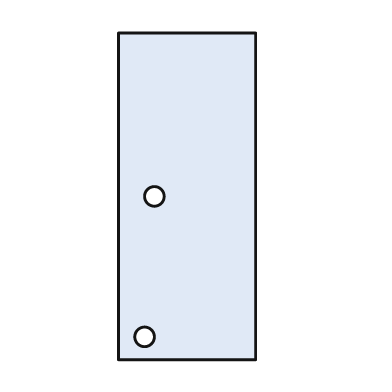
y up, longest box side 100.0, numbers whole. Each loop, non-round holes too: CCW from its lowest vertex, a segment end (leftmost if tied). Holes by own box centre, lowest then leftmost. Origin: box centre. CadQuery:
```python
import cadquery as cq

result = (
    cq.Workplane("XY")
    .moveTo(-21.0, -50.0)
    .lineTo(21.0, -50.0)
    .lineTo(21.0, 50.0)
    .lineTo(-21.0, 50.0)
    .close()
    .moveTo(-13.0, -43.0)
    .circle(3.0)
    .moveTo(-10.0, 0.0)
    .circle(3.0)
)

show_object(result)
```